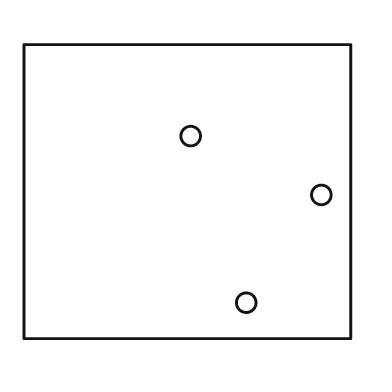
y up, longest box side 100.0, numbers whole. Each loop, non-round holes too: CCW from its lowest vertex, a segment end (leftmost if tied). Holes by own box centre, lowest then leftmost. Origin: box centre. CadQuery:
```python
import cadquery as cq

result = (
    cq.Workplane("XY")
    .moveTo(-50.0, -45.0)
    .lineTo(50.0, -45.0)
    .lineTo(50.0, 45.0)
    .lineTo(-50.0, 45.0)
    .close()
    .moveTo(18.0, -34.0)
    .circle(3.0)
    .moveTo(41.0, -1.0)
    .circle(3.0)
    .moveTo(1.0, 17.0)
    .circle(3.0)
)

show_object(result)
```